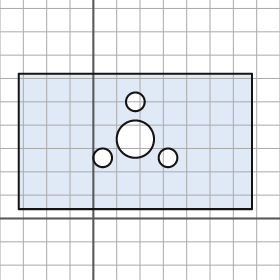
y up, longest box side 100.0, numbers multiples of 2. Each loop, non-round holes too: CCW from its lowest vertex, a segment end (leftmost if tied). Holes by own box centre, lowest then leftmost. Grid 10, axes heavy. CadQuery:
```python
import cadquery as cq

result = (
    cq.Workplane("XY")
    .moveTo(-32.0, 4.0)
    .lineTo(68.0, 4.0)
    .lineTo(68.0, 62.0)
    .lineTo(-32.0, 62.0)
    .close()
    .moveTo(4.0, 26.0)
    .circle(4.0)
    .moveTo(32.0, 26.0)
    .circle(4.0)
    .moveTo(18.0, 34.0)
    .circle(8.0)
    .moveTo(18.0, 50.0)
    .circle(4.0)
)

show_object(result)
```